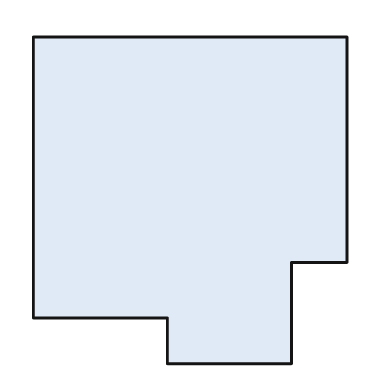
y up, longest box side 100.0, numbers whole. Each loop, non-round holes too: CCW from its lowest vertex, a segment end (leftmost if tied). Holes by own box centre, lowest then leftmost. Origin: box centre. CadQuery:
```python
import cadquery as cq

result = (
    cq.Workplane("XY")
    .moveTo(-7.0, -50.0)
    .lineTo(31.0, -50.0)
    .lineTo(31.0, -19.0)
    .lineTo(48.0, -19.0)
    .lineTo(48.0, 50.0)
    .lineTo(-48.0, 50.0)
    .lineTo(-48.0, -36.0)
    .lineTo(-7.0, -36.0)
    .close()
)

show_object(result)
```